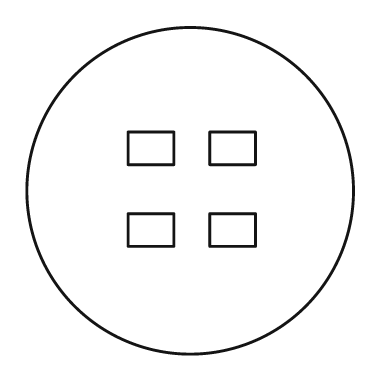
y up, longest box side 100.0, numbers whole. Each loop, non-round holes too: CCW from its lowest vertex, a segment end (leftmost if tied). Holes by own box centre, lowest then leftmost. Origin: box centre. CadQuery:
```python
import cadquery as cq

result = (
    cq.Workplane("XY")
    .moveTo(0.0, 0.0)
    .circle(50.0)
    .moveTo(-19.0, -17.0)
    .lineTo(-5.0, -17.0)
    .lineTo(-5.0, -7.0)
    .lineTo(-19.0, -7.0)
    .close()
    .moveTo(6.0, -17.0)
    .lineTo(20.0, -17.0)
    .lineTo(20.0, -7.0)
    .lineTo(6.0, -7.0)
    .close()
    .moveTo(-19.0, 8.0)
    .lineTo(-5.0, 8.0)
    .lineTo(-5.0, 18.0)
    .lineTo(-19.0, 18.0)
    .close()
    .moveTo(6.0, 8.0)
    .lineTo(20.0, 8.0)
    .lineTo(20.0, 18.0)
    .lineTo(6.0, 18.0)
    .close()
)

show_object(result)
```